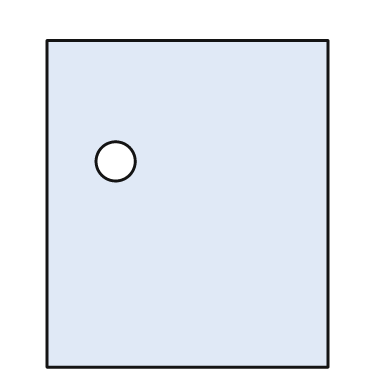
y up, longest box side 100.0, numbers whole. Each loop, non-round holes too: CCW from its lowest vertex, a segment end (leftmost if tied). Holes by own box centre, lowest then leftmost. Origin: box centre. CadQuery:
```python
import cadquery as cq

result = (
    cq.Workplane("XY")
    .moveTo(-43.0, -50.0)
    .lineTo(43.0, -50.0)
    .lineTo(43.0, 50.0)
    .lineTo(-43.0, 50.0)
    .close()
    .moveTo(-22.0, 13.0)
    .circle(6.0)
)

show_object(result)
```